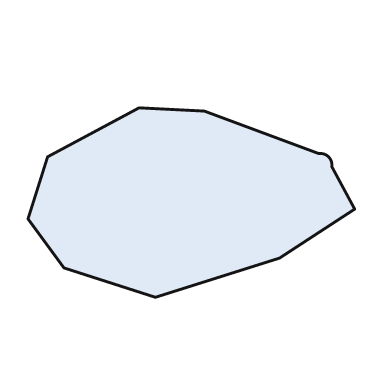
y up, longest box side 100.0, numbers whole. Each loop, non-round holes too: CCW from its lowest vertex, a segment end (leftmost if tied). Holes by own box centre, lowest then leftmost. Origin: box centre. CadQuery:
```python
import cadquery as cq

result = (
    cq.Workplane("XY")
    .moveTo(-11.0, -29.0)
    .lineTo(27.0, -17.0)
    .lineTo(50.0, -2.0)
    .lineTo(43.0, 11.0)
    .threePointArc((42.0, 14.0), (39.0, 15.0))
    .lineTo(4.0, 28.0)
    .lineTo(-16.0, 29.0)
    .lineTo(-44.0, 14.0)
    .lineTo(-50.0, -5.0)
    .lineTo(-39.0, -20.0)
    .close()
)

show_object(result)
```